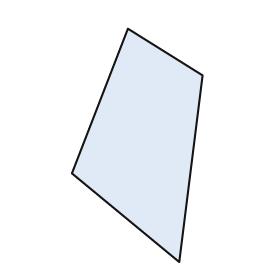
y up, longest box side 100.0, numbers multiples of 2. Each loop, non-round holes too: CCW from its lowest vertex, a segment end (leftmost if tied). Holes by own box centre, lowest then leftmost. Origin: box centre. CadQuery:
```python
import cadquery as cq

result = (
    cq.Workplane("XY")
    .moveTo(18.0, -50.0)
    .lineTo(28.0, 30.0)
    .lineTo(-4.0, 50.0)
    .lineTo(-28.0, -12.0)
    .close()
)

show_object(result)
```